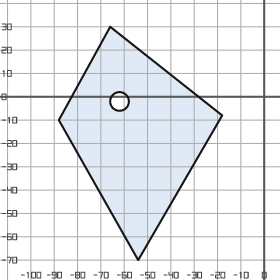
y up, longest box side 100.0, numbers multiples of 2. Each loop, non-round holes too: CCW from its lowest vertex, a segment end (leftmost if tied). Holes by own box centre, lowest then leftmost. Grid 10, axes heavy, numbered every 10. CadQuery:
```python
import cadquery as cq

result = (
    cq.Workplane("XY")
    .moveTo(-54.0, -70.0)
    .lineTo(-18.0, -8.0)
    .lineTo(-66.0, 30.0)
    .lineTo(-88.0, -10.0)
    .close()
    .moveTo(-62.0, -2.0)
    .circle(4.0)
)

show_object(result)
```